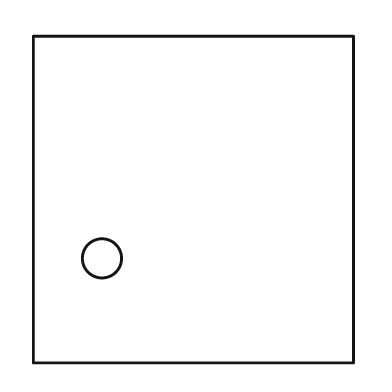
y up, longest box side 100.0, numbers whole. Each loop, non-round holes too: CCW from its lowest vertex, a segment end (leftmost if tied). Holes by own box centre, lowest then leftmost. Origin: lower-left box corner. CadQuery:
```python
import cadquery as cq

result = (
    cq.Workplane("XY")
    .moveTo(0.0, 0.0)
    .lineTo(98.0, 0.0)
    .lineTo(98.0, 100.0)
    .lineTo(0.0, 100.0)
    .close()
    .moveTo(21.0, 32.0)
    .circle(6.0)
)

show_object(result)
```